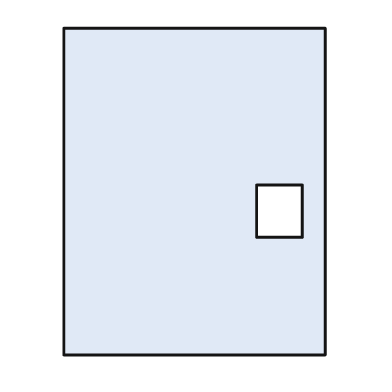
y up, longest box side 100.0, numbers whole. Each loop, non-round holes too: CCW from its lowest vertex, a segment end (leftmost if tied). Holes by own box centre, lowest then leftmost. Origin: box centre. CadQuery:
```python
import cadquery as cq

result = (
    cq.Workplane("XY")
    .moveTo(-40.0, -50.0)
    .lineTo(40.0, -50.0)
    .lineTo(40.0, 50.0)
    .lineTo(-40.0, 50.0)
    .close()
    .moveTo(19.0, -14.0)
    .lineTo(33.0, -14.0)
    .lineTo(33.0, 2.0)
    .lineTo(19.0, 2.0)
    .close()
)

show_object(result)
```